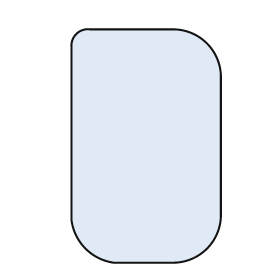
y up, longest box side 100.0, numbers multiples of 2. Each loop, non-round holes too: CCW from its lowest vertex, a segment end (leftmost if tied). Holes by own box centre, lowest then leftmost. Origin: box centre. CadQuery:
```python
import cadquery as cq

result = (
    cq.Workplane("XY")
    .moveTo(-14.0, -50.0)
    .lineTo(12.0, -50.0)
    .threePointArc((26.0, -44.0), (32.0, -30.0))
    .lineTo(32.0, 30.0)
    .threePointArc((26.0, 44.0), (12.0, 50.0))
    .lineTo(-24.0, 50.0)
    .threePointArc((-30.0, 48.0), (-32.0, 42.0))
    .lineTo(-32.0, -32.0)
    .threePointArc((-26.0, -44.0), (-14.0, -50.0))
    .close()
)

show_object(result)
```